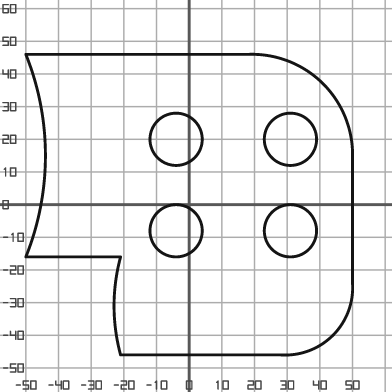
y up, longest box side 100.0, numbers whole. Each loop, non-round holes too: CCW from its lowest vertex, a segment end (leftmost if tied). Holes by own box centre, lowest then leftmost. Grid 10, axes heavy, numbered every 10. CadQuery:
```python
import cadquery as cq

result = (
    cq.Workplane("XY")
    .moveTo(-21.0, -46.0)
    .lineTo(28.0, -46.0)
    .threePointArc((44.0, -40.0), (50.0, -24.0))
    .lineTo(50.0, 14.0)
    .threePointArc((41.0, 37.0), (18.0, 46.0))
    .lineTo(-50.0, 46.0)
    .threePointArc((-44.0, 15.0), (-50.0, -16.0))
    .lineTo(-21.0, -16.0)
    .threePointArc((-23.0, -31.0), (-21.0, -46.0))
    .close()
    .moveTo(-4.0, -8.0)
    .circle(8.0)
    .moveTo(31.0, -8.0)
    .circle(8.0)
    .moveTo(-4.0, 20.0)
    .circle(8.0)
    .moveTo(31.0, 20.0)
    .circle(8.0)
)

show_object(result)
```